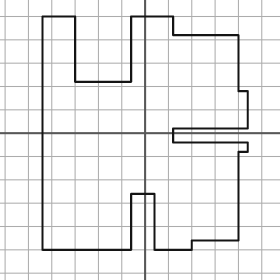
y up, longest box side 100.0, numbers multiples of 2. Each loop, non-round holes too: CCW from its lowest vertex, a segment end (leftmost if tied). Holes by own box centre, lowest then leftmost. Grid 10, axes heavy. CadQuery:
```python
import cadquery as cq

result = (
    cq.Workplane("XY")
    .moveTo(-44.0, -50.0)
    .lineTo(-6.0, -50.0)
    .lineTo(-6.0, -26.0)
    .lineTo(4.0, -26.0)
    .lineTo(4.0, -50.0)
    .lineTo(20.0, -50.0)
    .lineTo(20.0, -46.0)
    .lineTo(40.0, -46.0)
    .lineTo(40.0, -8.0)
    .lineTo(44.0, -8.0)
    .lineTo(44.0, -4.0)
    .lineTo(12.0, -4.0)
    .lineTo(12.0, 2.0)
    .lineTo(44.0, 2.0)
    .lineTo(44.0, 18.0)
    .lineTo(40.0, 18.0)
    .lineTo(40.0, 42.0)
    .lineTo(12.0, 42.0)
    .lineTo(12.0, 50.0)
    .lineTo(-6.0, 50.0)
    .lineTo(-6.0, 22.0)
    .lineTo(-30.0, 22.0)
    .lineTo(-30.0, 50.0)
    .lineTo(-44.0, 50.0)
    .close()
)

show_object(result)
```